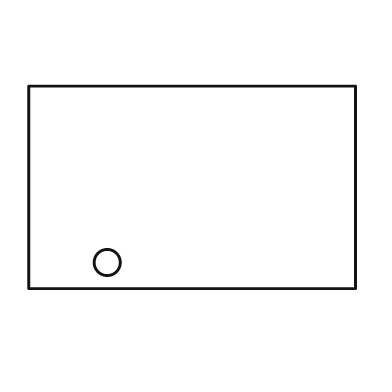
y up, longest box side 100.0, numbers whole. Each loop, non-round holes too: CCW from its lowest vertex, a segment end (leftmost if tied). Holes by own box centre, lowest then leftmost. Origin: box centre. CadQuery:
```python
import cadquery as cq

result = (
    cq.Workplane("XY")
    .moveTo(-50.0, -31.0)
    .lineTo(50.0, -31.0)
    .lineTo(50.0, 31.0)
    .lineTo(-50.0, 31.0)
    .close()
    .moveTo(-26.0, -23.0)
    .circle(4.0)
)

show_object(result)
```